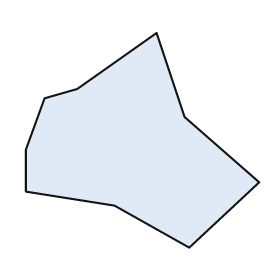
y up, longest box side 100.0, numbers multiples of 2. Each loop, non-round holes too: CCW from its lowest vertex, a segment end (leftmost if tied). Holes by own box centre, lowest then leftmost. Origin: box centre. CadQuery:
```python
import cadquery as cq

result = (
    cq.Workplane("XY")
    .moveTo(20.0, -46.0)
    .lineTo(50.0, -18.0)
    .lineTo(18.0, 10.0)
    .lineTo(6.0, 46.0)
    .lineTo(-28.0, 22.0)
    .lineTo(-42.0, 18.0)
    .lineTo(-50.0, -4.0)
    .lineTo(-50.0, -22.0)
    .lineTo(-12.0, -28.0)
    .close()
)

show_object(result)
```